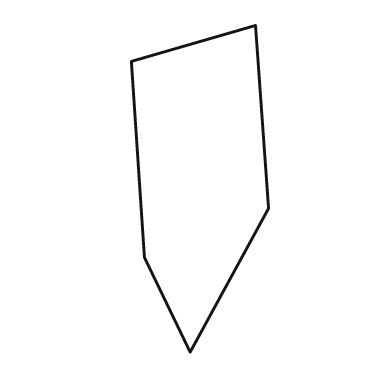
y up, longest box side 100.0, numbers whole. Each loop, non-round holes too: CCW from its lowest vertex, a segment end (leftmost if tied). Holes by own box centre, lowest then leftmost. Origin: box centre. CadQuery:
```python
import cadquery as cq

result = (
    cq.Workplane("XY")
    .moveTo(-3.0, -50.0)
    .lineTo(21.0, -6.0)
    .lineTo(17.0, 50.0)
    .lineTo(-21.0, 39.0)
    .lineTo(-17.0, -21.0)
    .close()
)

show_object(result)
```